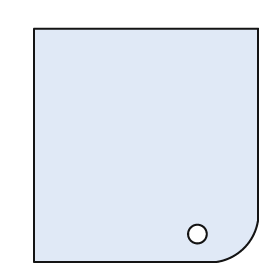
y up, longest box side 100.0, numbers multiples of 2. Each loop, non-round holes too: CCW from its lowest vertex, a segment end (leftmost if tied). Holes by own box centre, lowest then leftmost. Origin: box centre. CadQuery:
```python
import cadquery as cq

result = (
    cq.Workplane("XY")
    .moveTo(-48.0, -50.0)
    .lineTo(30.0, -50.0)
    .threePointArc((42.0, -44.0), (48.0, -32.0))
    .lineTo(48.0, 50.0)
    .lineTo(-48.0, 50.0)
    .close()
    .moveTo(22.0, -38.0)
    .circle(4.0)
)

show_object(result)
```